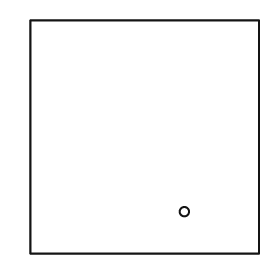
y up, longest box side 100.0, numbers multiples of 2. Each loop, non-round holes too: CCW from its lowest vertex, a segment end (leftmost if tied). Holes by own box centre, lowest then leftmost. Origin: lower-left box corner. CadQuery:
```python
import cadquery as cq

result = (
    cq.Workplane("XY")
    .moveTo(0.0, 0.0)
    .lineTo(98.0, 0.0)
    .lineTo(98.0, 100.0)
    .lineTo(0.0, 100.0)
    .close()
    .moveTo(66.0, 18.0)
    .circle(2.0)
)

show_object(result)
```